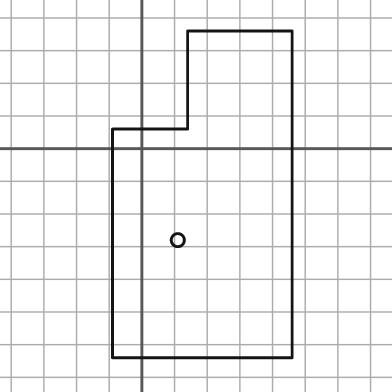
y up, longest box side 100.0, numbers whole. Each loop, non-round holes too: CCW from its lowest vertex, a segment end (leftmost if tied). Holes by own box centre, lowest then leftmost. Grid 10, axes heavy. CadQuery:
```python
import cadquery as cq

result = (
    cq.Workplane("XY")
    .moveTo(-9.0, -64.0)
    .lineTo(46.0, -64.0)
    .lineTo(46.0, 36.0)
    .lineTo(14.0, 36.0)
    .lineTo(14.0, 6.0)
    .lineTo(-9.0, 6.0)
    .close()
    .moveTo(11.0, -28.0)
    .circle(2.0)
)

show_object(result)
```